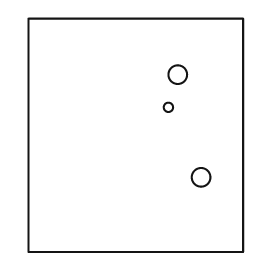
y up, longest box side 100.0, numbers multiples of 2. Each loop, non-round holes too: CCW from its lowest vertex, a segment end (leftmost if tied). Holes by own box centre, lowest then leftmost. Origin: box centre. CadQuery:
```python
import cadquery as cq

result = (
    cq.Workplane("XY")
    .moveTo(-46.0, -50.0)
    .lineTo(46.0, -50.0)
    .lineTo(46.0, 50.0)
    .lineTo(-46.0, 50.0)
    .close()
    .moveTo(28.0, -18.0)
    .circle(4.0)
    .moveTo(14.0, 12.0)
    .circle(2.0)
    .moveTo(18.0, 26.0)
    .circle(4.0)
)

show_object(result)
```